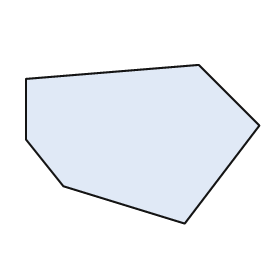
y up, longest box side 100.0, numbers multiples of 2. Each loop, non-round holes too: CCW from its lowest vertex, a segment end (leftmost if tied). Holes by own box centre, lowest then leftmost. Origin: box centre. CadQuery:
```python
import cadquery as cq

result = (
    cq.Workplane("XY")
    .moveTo(18.0, -34.0)
    .lineTo(50.0, 8.0)
    .lineTo(24.0, 34.0)
    .lineTo(-50.0, 28.0)
    .lineTo(-50.0, 2.0)
    .lineTo(-34.0, -18.0)
    .close()
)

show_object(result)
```